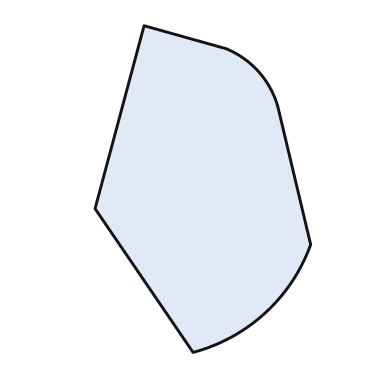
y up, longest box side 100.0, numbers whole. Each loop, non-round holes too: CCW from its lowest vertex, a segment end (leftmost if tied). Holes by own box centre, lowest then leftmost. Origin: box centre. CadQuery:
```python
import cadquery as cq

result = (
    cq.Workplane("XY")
    .moveTo(-3.0, -50.0)
    .threePointArc((19.0, -38.0), (33.0, -17.0))
    .lineTo(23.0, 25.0)
    .threePointArc((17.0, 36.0), (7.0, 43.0))
    .lineTo(-18.0, 50.0)
    .lineTo(-33.0, -6.0)
    .close()
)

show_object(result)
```